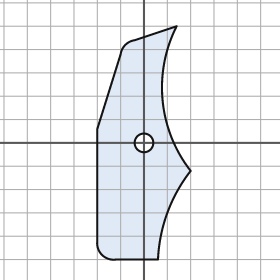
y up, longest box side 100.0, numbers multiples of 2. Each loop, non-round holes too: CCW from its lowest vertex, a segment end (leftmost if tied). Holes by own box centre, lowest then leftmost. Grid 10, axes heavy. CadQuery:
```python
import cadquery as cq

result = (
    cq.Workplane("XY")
    .moveTo(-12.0, -50.0)
    .lineTo(6.0, -50.0)
    .threePointArc((10.0, -30.0), (20.0, -12.0))
    .threePointArc((8.0, 18.0), (14.0, 50.0))
    .lineTo(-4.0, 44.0)
    .threePointArc((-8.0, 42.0), (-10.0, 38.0))
    .lineTo(-20.0, 6.0)
    .lineTo(-20.0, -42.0)
    .threePointArc((-18.0, -48.0), (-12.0, -50.0))
    .close()
    .moveTo(0.0, 0.0)
    .circle(4.0)
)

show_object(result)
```